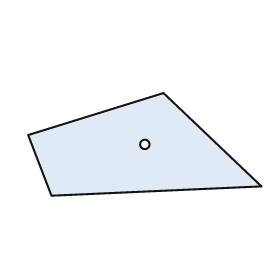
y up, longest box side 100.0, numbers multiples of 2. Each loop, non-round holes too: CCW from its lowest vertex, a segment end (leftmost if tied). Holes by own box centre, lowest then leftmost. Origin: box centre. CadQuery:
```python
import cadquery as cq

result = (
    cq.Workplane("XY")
    .moveTo(-40.0, -22.0)
    .lineTo(50.0, -18.0)
    .lineTo(8.0, 22.0)
    .lineTo(-50.0, 4.0)
    .close()
    .moveTo(0.0, 0.0)
    .circle(2.0)
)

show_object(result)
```